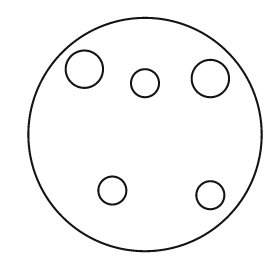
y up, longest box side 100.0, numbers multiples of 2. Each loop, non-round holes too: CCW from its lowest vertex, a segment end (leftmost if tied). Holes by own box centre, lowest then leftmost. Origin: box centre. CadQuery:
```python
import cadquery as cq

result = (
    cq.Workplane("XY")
    .moveTo(0.0, 0.0)
    .circle(50.0)
    .moveTo(28.0, -26.0)
    .circle(6.0)
    .moveTo(-14.0, -24.0)
    .circle(6.0)
    .moveTo(0.0, 22.0)
    .circle(6.0)
    .moveTo(28.0, 24.0)
    .circle(8.0)
    .moveTo(-26.0, 28.0)
    .circle(8.0)
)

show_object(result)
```